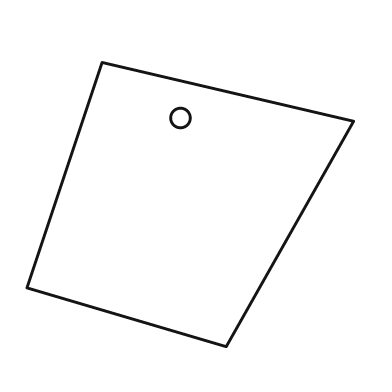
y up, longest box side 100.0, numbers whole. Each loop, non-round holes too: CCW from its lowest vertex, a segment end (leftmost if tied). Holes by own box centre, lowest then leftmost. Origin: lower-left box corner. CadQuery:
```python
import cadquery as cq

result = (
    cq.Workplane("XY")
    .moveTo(61.0, 0.0)
    .lineTo(100.0, 69.0)
    .lineTo(23.0, 87.0)
    .lineTo(0.0, 18.0)
    .close()
    .moveTo(47.0, 70.0)
    .circle(3.0)
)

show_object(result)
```